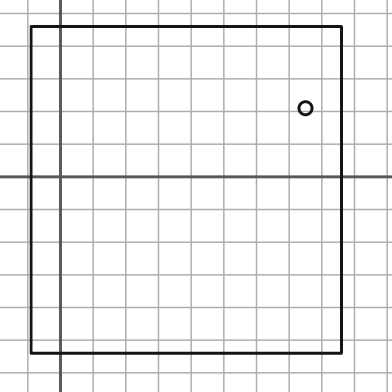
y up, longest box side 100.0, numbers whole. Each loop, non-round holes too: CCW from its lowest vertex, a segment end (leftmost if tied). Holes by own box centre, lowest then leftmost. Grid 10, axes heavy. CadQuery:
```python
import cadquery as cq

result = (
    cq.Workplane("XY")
    .moveTo(-9.0, -54.0)
    .lineTo(86.0, -54.0)
    .lineTo(86.0, 46.0)
    .lineTo(-9.0, 46.0)
    .close()
    .moveTo(75.0, 21.0)
    .circle(2.0)
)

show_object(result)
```